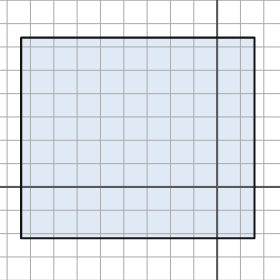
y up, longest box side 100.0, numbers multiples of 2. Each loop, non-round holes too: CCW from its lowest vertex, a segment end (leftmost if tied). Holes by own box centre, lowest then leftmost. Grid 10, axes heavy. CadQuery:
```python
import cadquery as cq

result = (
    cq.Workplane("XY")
    .moveTo(-84.0, -22.0)
    .lineTo(16.0, -22.0)
    .lineTo(16.0, 64.0)
    .lineTo(-84.0, 64.0)
    .close()
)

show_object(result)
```